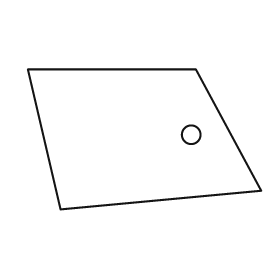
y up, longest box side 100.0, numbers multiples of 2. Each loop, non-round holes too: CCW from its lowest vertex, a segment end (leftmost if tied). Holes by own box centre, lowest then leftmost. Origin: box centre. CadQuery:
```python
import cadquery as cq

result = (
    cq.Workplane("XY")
    .moveTo(-36.0, -30.0)
    .lineTo(50.0, -22.0)
    .lineTo(22.0, 30.0)
    .lineTo(-50.0, 30.0)
    .close()
    .moveTo(20.0, 2.0)
    .circle(4.0)
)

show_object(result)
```